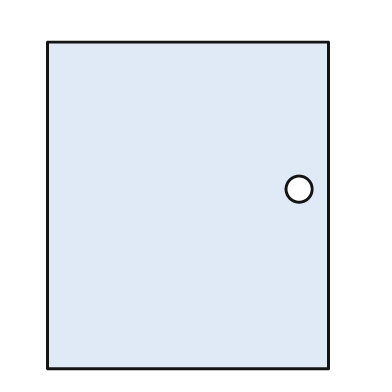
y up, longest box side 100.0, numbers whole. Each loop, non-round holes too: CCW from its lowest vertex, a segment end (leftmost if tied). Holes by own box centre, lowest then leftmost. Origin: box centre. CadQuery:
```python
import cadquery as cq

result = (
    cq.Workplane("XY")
    .moveTo(-43.0, -50.0)
    .lineTo(43.0, -50.0)
    .lineTo(43.0, 50.0)
    .lineTo(-43.0, 50.0)
    .close()
    .moveTo(34.0, 5.0)
    .circle(4.0)
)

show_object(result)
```